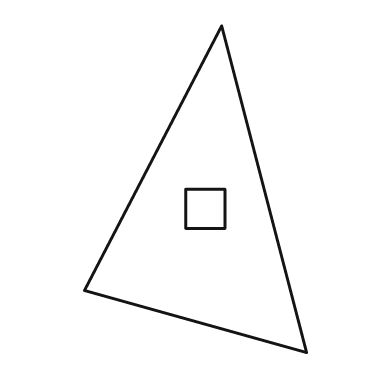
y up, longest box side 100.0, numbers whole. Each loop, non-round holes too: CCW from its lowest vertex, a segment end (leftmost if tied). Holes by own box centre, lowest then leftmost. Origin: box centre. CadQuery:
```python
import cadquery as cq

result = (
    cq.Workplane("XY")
    .moveTo(34.0, -50.0)
    .lineTo(8.0, 50.0)
    .lineTo(-34.0, -31.0)
    .close()
    .moveTo(-3.0, -12.0)
    .lineTo(9.0, -12.0)
    .lineTo(9.0, 0.0)
    .lineTo(-3.0, 0.0)
    .close()
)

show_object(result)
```